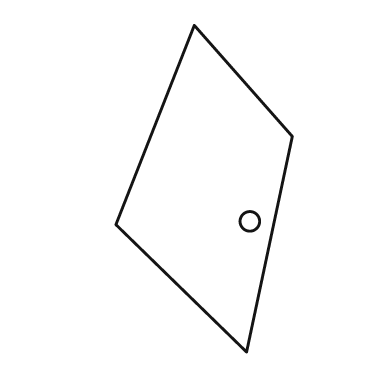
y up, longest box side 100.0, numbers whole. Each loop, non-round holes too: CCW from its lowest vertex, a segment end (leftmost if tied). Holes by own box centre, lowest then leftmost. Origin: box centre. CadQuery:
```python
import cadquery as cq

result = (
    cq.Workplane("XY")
    .moveTo(13.0, -50.0)
    .lineTo(27.0, 16.0)
    .lineTo(-3.0, 50.0)
    .lineTo(-27.0, -11.0)
    .close()
    .moveTo(14.0, -10.0)
    .circle(3.0)
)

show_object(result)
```